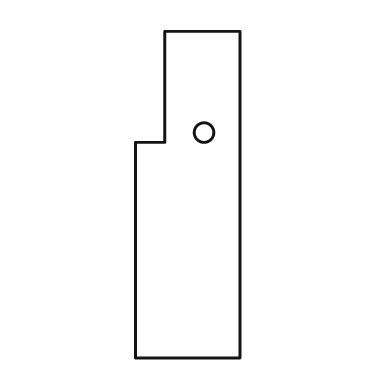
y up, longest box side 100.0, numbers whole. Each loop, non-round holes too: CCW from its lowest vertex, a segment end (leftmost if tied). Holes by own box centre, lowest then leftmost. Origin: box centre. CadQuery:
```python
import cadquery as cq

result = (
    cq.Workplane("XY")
    .moveTo(-16.0, -50.0)
    .lineTo(16.0, -50.0)
    .lineTo(16.0, 50.0)
    .lineTo(-7.0, 50.0)
    .lineTo(-7.0, 16.0)
    .lineTo(-16.0, 16.0)
    .close()
    .moveTo(5.0, 19.0)
    .circle(3.0)
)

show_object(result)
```